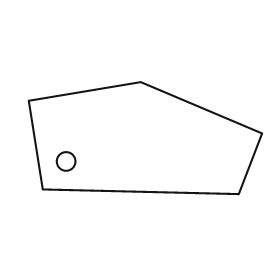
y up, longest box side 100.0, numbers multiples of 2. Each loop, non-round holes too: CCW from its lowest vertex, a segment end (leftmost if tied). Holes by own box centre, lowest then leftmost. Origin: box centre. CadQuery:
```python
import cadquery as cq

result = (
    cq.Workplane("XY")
    .moveTo(40.0, -24.0)
    .lineTo(50.0, 2.0)
    .lineTo(-2.0, 24.0)
    .lineTo(-50.0, 16.0)
    .lineTo(-44.0, -22.0)
    .close()
    .moveTo(-34.0, -10.0)
    .circle(4.0)
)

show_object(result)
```